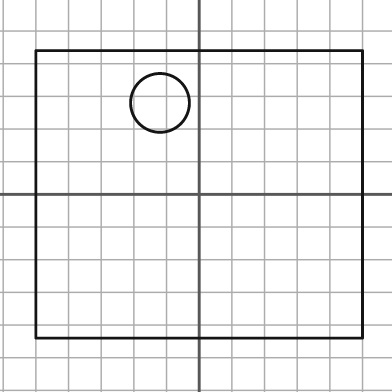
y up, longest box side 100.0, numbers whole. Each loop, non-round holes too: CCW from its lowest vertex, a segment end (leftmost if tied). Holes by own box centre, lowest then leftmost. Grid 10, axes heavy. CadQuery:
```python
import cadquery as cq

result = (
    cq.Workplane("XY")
    .moveTo(-50.0, -44.0)
    .lineTo(50.0, -44.0)
    .lineTo(50.0, 44.0)
    .lineTo(-50.0, 44.0)
    .close()
    .moveTo(-12.0, 28.0)
    .circle(9.0)
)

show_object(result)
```